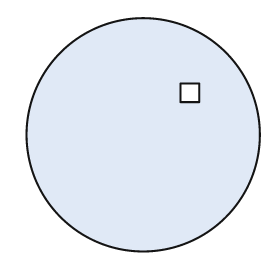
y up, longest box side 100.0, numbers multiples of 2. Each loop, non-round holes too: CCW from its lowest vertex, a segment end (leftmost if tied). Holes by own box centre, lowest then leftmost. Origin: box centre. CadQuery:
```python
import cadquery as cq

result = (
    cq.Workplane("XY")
    .moveTo(0.0, 0.0)
    .circle(50.0)
    .moveTo(16.0, 14.0)
    .lineTo(24.0, 14.0)
    .lineTo(24.0, 22.0)
    .lineTo(16.0, 22.0)
    .close()
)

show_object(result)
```